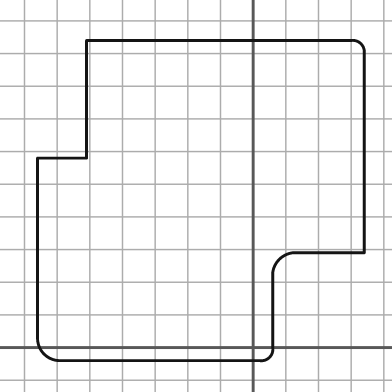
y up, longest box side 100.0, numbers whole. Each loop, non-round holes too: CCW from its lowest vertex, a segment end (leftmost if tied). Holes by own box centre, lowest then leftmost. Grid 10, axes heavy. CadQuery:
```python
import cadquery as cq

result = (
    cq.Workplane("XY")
    .moveTo(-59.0, -4.0)
    .lineTo(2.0, -4.0)
    .threePointArc((5.0, -3.0), (6.0, 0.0))
    .lineTo(6.0, 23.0)
    .threePointArc((8.0, 27.0), (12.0, 29.0))
    .lineTo(34.0, 29.0)
    .lineTo(34.0, 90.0)
    .threePointArc((33.0, 93.0), (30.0, 94.0))
    .lineTo(-51.0, 94.0)
    .lineTo(-51.0, 58.0)
    .lineTo(-66.0, 58.0)
    .lineTo(-66.0, 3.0)
    .threePointArc((-64.0, -2.0), (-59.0, -4.0))
    .close()
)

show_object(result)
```